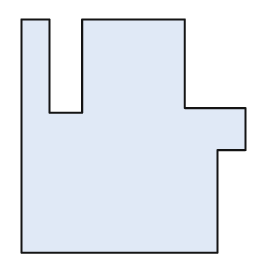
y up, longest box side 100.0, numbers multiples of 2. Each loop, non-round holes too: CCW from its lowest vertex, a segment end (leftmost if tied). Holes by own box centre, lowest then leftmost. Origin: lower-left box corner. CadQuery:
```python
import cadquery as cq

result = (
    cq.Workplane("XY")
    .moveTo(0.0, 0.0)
    .lineTo(84.0, 0.0)
    .lineTo(84.0, 44.0)
    .lineTo(96.0, 44.0)
    .lineTo(96.0, 62.0)
    .lineTo(70.0, 62.0)
    .lineTo(70.0, 100.0)
    .lineTo(26.0, 100.0)
    .lineTo(26.0, 60.0)
    .lineTo(12.0, 60.0)
    .lineTo(12.0, 100.0)
    .lineTo(0.0, 100.0)
    .close()
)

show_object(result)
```